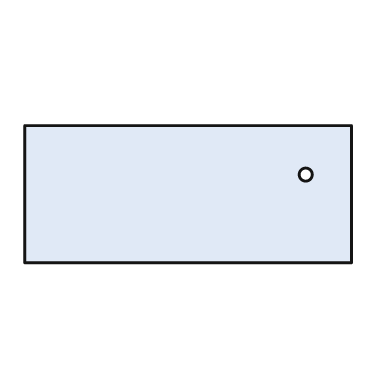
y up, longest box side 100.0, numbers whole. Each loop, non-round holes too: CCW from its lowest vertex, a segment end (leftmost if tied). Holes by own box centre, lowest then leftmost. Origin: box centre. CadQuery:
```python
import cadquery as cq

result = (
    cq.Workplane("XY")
    .moveTo(-50.0, -21.0)
    .lineTo(50.0, -21.0)
    .lineTo(50.0, 21.0)
    .lineTo(-50.0, 21.0)
    .close()
    .moveTo(36.0, 6.0)
    .circle(2.0)
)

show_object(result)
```